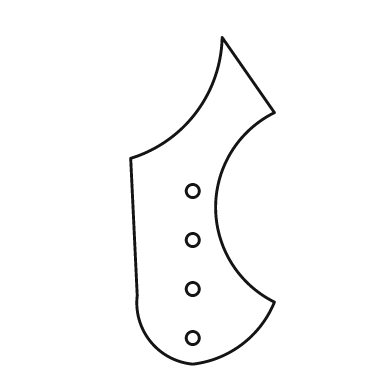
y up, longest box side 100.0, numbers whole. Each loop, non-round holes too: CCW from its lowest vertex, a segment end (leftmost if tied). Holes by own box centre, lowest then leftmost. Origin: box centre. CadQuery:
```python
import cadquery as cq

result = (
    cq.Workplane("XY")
    .moveTo(-3.0, -50.0)
    .threePointArc((12.0, -44.0), (22.0, -31.0))
    .threePointArc((4.0, -2.0), (22.0, 27.0))
    .lineTo(6.0, 50.0)
    .threePointArc((-2.0, 27.0), (-22.0, 13.0))
    .lineTo(-20.0, -29.0)
    .threePointArc((-16.0, -43.0), (-3.0, -50.0))
    .close()
    .moveTo(-3.0, -42.0)
    .circle(2.0)
    .moveTo(-3.0, -27.0)
    .circle(2.0)
    .moveTo(-3.0, -12.0)
    .circle(2.0)
    .moveTo(-3.0, 3.0)
    .circle(2.0)
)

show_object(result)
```